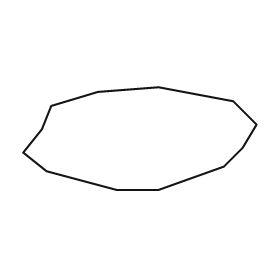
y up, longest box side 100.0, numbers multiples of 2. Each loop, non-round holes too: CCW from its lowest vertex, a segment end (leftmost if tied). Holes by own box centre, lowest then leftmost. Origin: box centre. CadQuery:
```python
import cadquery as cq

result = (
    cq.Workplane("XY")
    .moveTo(-10.0, -22.0)
    .lineTo(8.0, -22.0)
    .lineTo(36.0, -12.0)
    .lineTo(44.0, -4.0)
    .lineTo(50.0, 6.0)
    .lineTo(40.0, 16.0)
    .lineTo(8.0, 22.0)
    .lineTo(-18.0, 20.0)
    .lineTo(-38.0, 14.0)
    .lineTo(-42.0, 4.0)
    .lineTo(-50.0, -6.0)
    .lineTo(-40.0, -14.0)
    .close()
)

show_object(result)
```